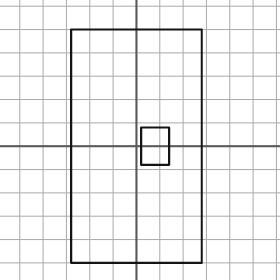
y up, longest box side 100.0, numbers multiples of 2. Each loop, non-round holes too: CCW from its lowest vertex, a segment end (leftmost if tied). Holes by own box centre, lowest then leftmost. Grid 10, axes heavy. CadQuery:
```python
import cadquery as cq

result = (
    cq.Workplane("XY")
    .moveTo(-28.0, -50.0)
    .lineTo(28.0, -50.0)
    .lineTo(28.0, 50.0)
    .lineTo(-28.0, 50.0)
    .close()
    .moveTo(2.0, -8.0)
    .lineTo(14.0, -8.0)
    .lineTo(14.0, 8.0)
    .lineTo(2.0, 8.0)
    .close()
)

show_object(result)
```